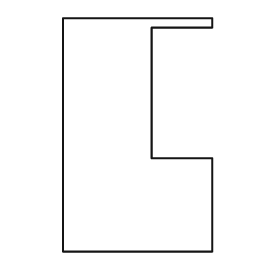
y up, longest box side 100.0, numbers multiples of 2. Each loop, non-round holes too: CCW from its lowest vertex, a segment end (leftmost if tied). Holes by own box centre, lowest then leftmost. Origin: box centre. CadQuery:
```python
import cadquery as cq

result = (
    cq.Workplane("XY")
    .moveTo(-32.0, -50.0)
    .lineTo(32.0, -50.0)
    .lineTo(32.0, -10.0)
    .lineTo(6.0, -10.0)
    .lineTo(6.0, 46.0)
    .lineTo(32.0, 46.0)
    .lineTo(32.0, 50.0)
    .lineTo(-32.0, 50.0)
    .close()
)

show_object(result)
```